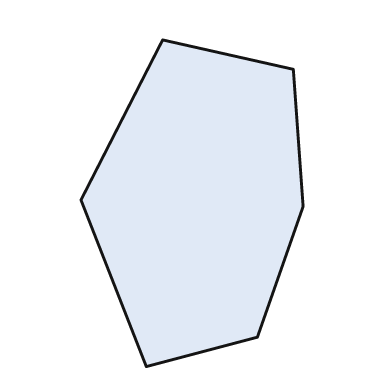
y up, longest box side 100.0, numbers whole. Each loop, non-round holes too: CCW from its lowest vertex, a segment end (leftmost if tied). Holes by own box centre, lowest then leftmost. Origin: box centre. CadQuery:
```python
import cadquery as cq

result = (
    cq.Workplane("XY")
    .moveTo(-14.0, -50.0)
    .lineTo(20.0, -41.0)
    .lineTo(34.0, -1.0)
    .lineTo(31.0, 41.0)
    .lineTo(-9.0, 50.0)
    .lineTo(-34.0, 1.0)
    .close()
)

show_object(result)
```